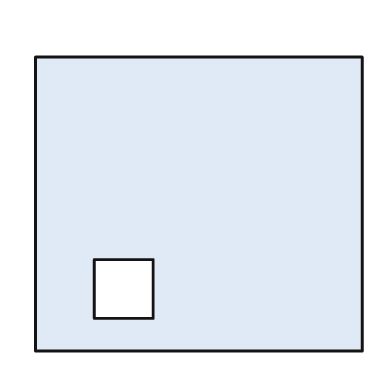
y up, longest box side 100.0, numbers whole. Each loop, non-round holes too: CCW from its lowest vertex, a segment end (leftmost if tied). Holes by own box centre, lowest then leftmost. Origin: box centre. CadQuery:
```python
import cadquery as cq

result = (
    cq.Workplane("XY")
    .moveTo(-50.0, -45.0)
    .lineTo(50.0, -45.0)
    .lineTo(50.0, 45.0)
    .lineTo(-50.0, 45.0)
    .close()
    .moveTo(-32.0, -35.0)
    .lineTo(-14.0, -35.0)
    .lineTo(-14.0, -17.0)
    .lineTo(-32.0, -17.0)
    .close()
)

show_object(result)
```